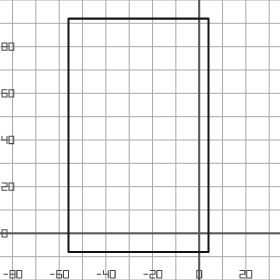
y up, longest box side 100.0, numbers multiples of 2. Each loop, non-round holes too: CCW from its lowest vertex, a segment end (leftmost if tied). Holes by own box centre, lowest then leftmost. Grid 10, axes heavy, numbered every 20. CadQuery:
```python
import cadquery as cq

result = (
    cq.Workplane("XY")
    .moveTo(-56.0, -8.0)
    .lineTo(4.0, -8.0)
    .lineTo(4.0, 92.0)
    .lineTo(-56.0, 92.0)
    .close()
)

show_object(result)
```